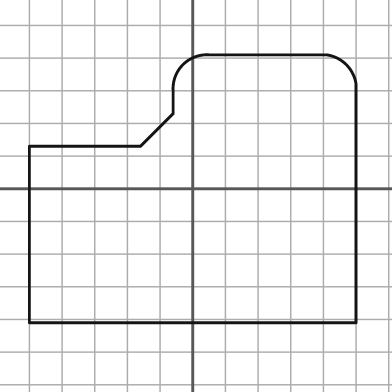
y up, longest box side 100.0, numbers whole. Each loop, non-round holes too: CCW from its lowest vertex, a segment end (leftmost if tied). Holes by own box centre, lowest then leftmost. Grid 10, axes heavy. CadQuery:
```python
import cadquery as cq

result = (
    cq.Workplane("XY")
    .moveTo(-50.0, -41.0)
    .lineTo(50.0, -41.0)
    .lineTo(50.0, 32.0)
    .threePointArc((47.0, 38.0), (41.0, 41.0))
    .lineTo(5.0, 41.0)
    .threePointArc((-3.0, 38.0), (-6.0, 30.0))
    .lineTo(-6.0, 23.0)
    .lineTo(-16.0, 13.0)
    .lineTo(-50.0, 13.0)
    .close()
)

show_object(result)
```